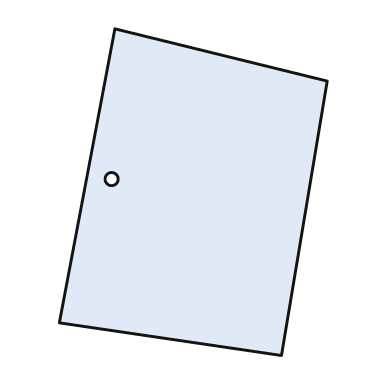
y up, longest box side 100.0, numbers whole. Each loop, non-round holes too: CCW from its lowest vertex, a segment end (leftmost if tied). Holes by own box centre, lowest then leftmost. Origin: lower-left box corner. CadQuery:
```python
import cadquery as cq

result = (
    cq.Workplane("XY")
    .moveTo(68.0, 0.0)
    .lineTo(82.0, 84.0)
    .lineTo(17.0, 100.0)
    .lineTo(0.0, 10.0)
    .close()
    .moveTo(16.0, 54.0)
    .circle(2.0)
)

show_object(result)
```